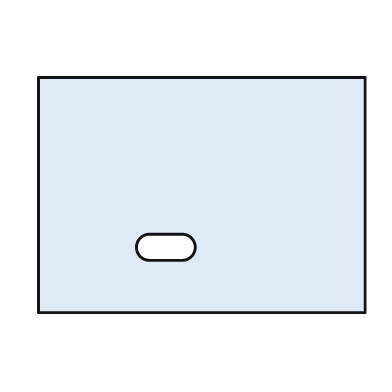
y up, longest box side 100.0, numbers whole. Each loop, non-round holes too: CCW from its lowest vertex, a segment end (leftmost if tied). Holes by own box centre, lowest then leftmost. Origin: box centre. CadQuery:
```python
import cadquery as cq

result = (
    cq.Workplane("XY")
    .moveTo(-50.0, -36.0)
    .lineTo(50.0, -36.0)
    .lineTo(50.0, 36.0)
    .lineTo(-50.0, 36.0)
    .close()
    .moveTo(-16.0, -20.0)
    .lineTo(-6.0, -20.0)
    .threePointArc((-2.0, -16.0), (-6.0, -12.0))
    .lineTo(-16.0, -12.0)
    .threePointArc((-20.0, -16.0), (-16.0, -20.0))
    .close()
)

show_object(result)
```